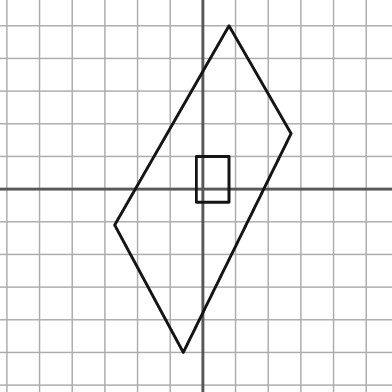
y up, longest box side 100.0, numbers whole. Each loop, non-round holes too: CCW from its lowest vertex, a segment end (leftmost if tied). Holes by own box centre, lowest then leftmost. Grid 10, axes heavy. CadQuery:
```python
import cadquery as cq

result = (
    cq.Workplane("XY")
    .moveTo(-6.0, -50.0)
    .lineTo(27.0, 17.0)
    .lineTo(8.0, 50.0)
    .lineTo(-27.0, -11.0)
    .close()
    .moveTo(-2.0, -4.0)
    .lineTo(8.0, -4.0)
    .lineTo(8.0, 10.0)
    .lineTo(-2.0, 10.0)
    .close()
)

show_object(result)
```